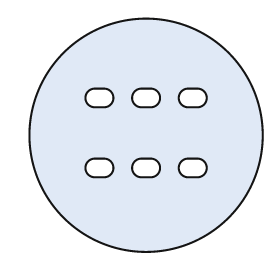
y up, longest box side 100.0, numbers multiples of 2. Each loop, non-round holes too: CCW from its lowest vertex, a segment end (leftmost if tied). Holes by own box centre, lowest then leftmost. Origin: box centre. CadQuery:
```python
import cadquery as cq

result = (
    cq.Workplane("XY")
    .moveTo(0.0, 0.0)
    .circle(50.0)
    .moveTo(-22.0, -18.0)
    .lineTo(-18.0, -18.0)
    .threePointArc((-14.0, -14.0), (-18.0, -10.0))
    .lineTo(-22.0, -10.0)
    .threePointArc((-26.0, -14.0), (-22.0, -18.0))
    .close()
    .moveTo(-2.0, -18.0)
    .lineTo(2.0, -18.0)
    .threePointArc((6.0, -14.0), (2.0, -10.0))
    .lineTo(-2.0, -10.0)
    .threePointArc((-6.0, -14.0), (-2.0, -18.0))
    .close()
    .moveTo(18.0, -18.0)
    .lineTo(22.0, -18.0)
    .threePointArc((26.0, -14.0), (22.0, -10.0))
    .lineTo(18.0, -10.0)
    .threePointArc((14.0, -14.0), (18.0, -18.0))
    .close()
    .moveTo(-22.0, 12.0)
    .lineTo(-18.0, 12.0)
    .threePointArc((-14.0, 16.0), (-18.0, 20.0))
    .lineTo(-22.0, 20.0)
    .threePointArc((-26.0, 16.0), (-22.0, 12.0))
    .close()
    .moveTo(-2.0, 12.0)
    .lineTo(2.0, 12.0)
    .threePointArc((6.0, 16.0), (2.0, 20.0))
    .lineTo(-2.0, 20.0)
    .threePointArc((-6.0, 16.0), (-2.0, 12.0))
    .close()
    .moveTo(18.0, 12.0)
    .lineTo(22.0, 12.0)
    .threePointArc((26.0, 16.0), (22.0, 20.0))
    .lineTo(18.0, 20.0)
    .threePointArc((14.0, 16.0), (18.0, 12.0))
    .close()
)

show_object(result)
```